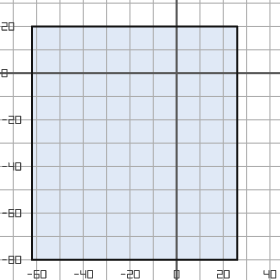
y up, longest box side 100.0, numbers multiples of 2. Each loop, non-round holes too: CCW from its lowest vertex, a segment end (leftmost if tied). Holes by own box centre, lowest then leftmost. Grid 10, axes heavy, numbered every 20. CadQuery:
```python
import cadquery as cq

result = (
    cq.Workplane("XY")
    .moveTo(-62.0, -80.0)
    .lineTo(26.0, -80.0)
    .lineTo(26.0, 20.0)
    .lineTo(-62.0, 20.0)
    .close()
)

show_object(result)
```